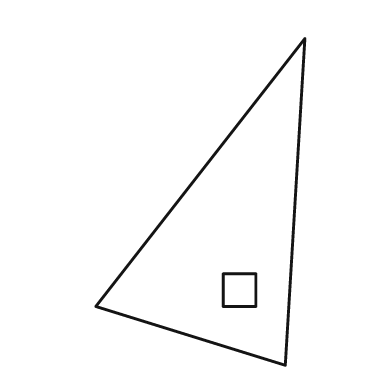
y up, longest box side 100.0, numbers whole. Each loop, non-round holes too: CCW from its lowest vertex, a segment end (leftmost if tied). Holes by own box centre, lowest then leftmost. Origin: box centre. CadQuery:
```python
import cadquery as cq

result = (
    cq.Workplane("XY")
    .moveTo(26.0, -50.0)
    .lineTo(32.0, 50.0)
    .lineTo(-32.0, -32.0)
    .close()
    .moveTo(7.0, -32.0)
    .lineTo(17.0, -32.0)
    .lineTo(17.0, -22.0)
    .lineTo(7.0, -22.0)
    .close()
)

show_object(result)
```